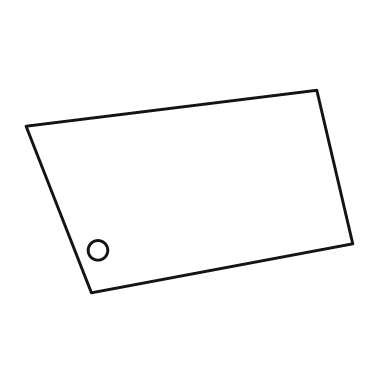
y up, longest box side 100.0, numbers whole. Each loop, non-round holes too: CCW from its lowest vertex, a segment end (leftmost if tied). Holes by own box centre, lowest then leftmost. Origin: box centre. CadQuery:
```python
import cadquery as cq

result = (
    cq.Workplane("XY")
    .moveTo(-30.0, -31.0)
    .lineTo(50.0, -16.0)
    .lineTo(39.0, 31.0)
    .lineTo(-50.0, 20.0)
    .close()
    .moveTo(-28.0, -18.0)
    .circle(3.0)
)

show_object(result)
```